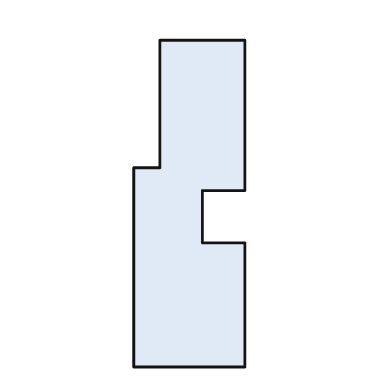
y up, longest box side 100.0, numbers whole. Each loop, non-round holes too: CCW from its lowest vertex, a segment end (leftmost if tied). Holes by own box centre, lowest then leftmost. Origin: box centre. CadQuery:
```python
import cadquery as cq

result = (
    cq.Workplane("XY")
    .moveTo(-17.0, -50.0)
    .lineTo(17.0, -50.0)
    .lineTo(17.0, -12.0)
    .lineTo(4.0, -12.0)
    .lineTo(4.0, 4.0)
    .lineTo(17.0, 4.0)
    .lineTo(17.0, 50.0)
    .lineTo(-9.0, 50.0)
    .lineTo(-9.0, 11.0)
    .lineTo(-17.0, 11.0)
    .close()
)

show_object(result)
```